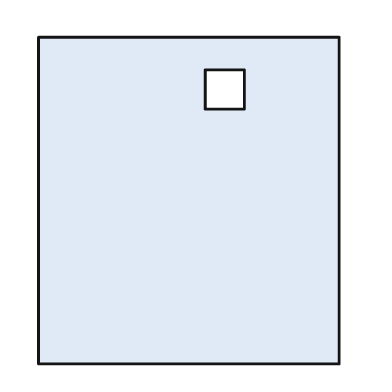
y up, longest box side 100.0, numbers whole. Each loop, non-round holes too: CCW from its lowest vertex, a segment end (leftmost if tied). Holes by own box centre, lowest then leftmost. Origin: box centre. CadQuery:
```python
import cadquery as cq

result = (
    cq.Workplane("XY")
    .moveTo(-46.0, -50.0)
    .lineTo(46.0, -50.0)
    .lineTo(46.0, 50.0)
    .lineTo(-46.0, 50.0)
    .close()
    .moveTo(5.0, 28.0)
    .lineTo(17.0, 28.0)
    .lineTo(17.0, 40.0)
    .lineTo(5.0, 40.0)
    .close()
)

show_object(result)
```